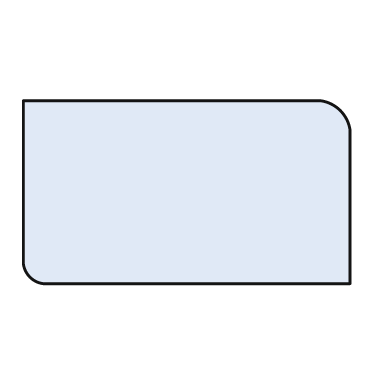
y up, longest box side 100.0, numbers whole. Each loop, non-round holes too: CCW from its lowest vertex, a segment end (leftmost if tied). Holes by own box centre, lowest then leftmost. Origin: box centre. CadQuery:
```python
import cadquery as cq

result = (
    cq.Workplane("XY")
    .moveTo(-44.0, -28.0)
    .lineTo(50.0, -28.0)
    .lineTo(50.0, 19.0)
    .threePointArc((47.0, 25.0), (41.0, 28.0))
    .lineTo(-50.0, 28.0)
    .lineTo(-50.0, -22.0)
    .threePointArc((-48.0, -26.0), (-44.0, -28.0))
    .close()
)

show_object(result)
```